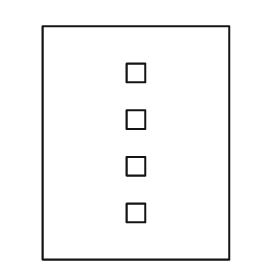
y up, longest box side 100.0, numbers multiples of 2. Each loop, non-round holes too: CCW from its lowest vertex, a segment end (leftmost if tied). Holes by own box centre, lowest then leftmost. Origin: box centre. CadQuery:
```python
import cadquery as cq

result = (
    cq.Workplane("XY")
    .moveTo(-40.0, -50.0)
    .lineTo(40.0, -50.0)
    .lineTo(40.0, 50.0)
    .lineTo(-40.0, 50.0)
    .close()
    .moveTo(-4.0, -34.0)
    .lineTo(4.0, -34.0)
    .lineTo(4.0, -26.0)
    .lineTo(-4.0, -26.0)
    .close()
    .moveTo(-4.0, -14.0)
    .lineTo(4.0, -14.0)
    .lineTo(4.0, -6.0)
    .lineTo(-4.0, -6.0)
    .close()
    .moveTo(-4.0, 6.0)
    .lineTo(4.0, 6.0)
    .lineTo(4.0, 14.0)
    .lineTo(-4.0, 14.0)
    .close()
    .moveTo(-4.0, 26.0)
    .lineTo(4.0, 26.0)
    .lineTo(4.0, 34.0)
    .lineTo(-4.0, 34.0)
    .close()
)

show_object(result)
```